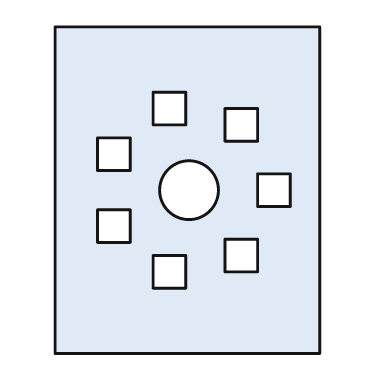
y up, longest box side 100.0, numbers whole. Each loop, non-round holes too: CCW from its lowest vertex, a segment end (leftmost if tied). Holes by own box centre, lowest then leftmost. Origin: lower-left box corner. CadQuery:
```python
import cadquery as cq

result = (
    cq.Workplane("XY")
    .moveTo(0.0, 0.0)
    .lineTo(81.0, 0.0)
    .lineTo(81.0, 100.0)
    .lineTo(0.0, 100.0)
    .close()
    .moveTo(30.0, 20.0)
    .lineTo(40.0, 20.0)
    .lineTo(40.0, 30.0)
    .lineTo(30.0, 30.0)
    .close()
    .moveTo(52.0, 25.0)
    .lineTo(62.0, 25.0)
    .lineTo(62.0, 35.0)
    .lineTo(52.0, 35.0)
    .close()
    .moveTo(13.0, 34.0)
    .lineTo(23.0, 34.0)
    .lineTo(23.0, 44.0)
    .lineTo(13.0, 44.0)
    .close()
    .moveTo(41.0, 50.0)
    .circle(9.0)
    .moveTo(62.0, 45.0)
    .lineTo(72.0, 45.0)
    .lineTo(72.0, 55.0)
    .lineTo(62.0, 55.0)
    .close()
    .moveTo(13.0, 56.0)
    .lineTo(23.0, 56.0)
    .lineTo(23.0, 66.0)
    .lineTo(13.0, 66.0)
    .close()
    .moveTo(52.0, 65.0)
    .lineTo(62.0, 65.0)
    .lineTo(62.0, 75.0)
    .lineTo(52.0, 75.0)
    .close()
    .moveTo(30.0, 70.0)
    .lineTo(40.0, 70.0)
    .lineTo(40.0, 80.0)
    .lineTo(30.0, 80.0)
    .close()
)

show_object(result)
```